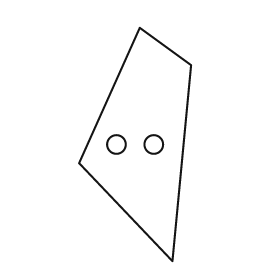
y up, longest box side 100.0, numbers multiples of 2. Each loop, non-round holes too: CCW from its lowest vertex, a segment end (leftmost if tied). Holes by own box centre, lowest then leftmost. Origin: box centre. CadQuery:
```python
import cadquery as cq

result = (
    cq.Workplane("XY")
    .moveTo(16.0, -50.0)
    .lineTo(24.0, 34.0)
    .lineTo(2.0, 50.0)
    .lineTo(-24.0, -8.0)
    .close()
    .moveTo(-8.0, 0.0)
    .circle(4.0)
    .moveTo(8.0, 0.0)
    .circle(4.0)
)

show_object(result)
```